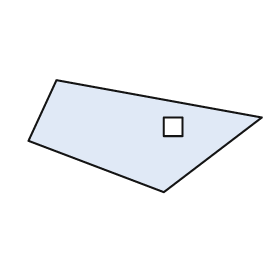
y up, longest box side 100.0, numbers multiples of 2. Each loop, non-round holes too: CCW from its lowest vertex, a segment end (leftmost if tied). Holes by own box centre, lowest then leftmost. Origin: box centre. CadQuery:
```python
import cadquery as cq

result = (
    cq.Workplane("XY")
    .moveTo(8.0, -24.0)
    .lineTo(50.0, 8.0)
    .lineTo(-38.0, 24.0)
    .lineTo(-50.0, -2.0)
    .close()
    .moveTo(8.0, 0.0)
    .lineTo(16.0, 0.0)
    .lineTo(16.0, 8.0)
    .lineTo(8.0, 8.0)
    .close()
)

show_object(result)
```